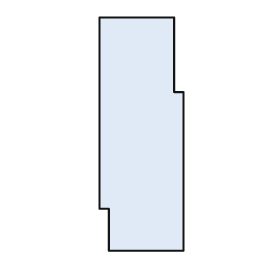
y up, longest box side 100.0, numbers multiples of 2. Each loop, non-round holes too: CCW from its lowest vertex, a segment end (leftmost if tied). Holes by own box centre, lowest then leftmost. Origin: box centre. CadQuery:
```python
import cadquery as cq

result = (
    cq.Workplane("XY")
    .moveTo(-14.0, -50.0)
    .lineTo(18.0, -50.0)
    .lineTo(18.0, 18.0)
    .lineTo(14.0, 18.0)
    .lineTo(14.0, 50.0)
    .lineTo(-18.0, 50.0)
    .lineTo(-18.0, -32.0)
    .lineTo(-14.0, -32.0)
    .close()
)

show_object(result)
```